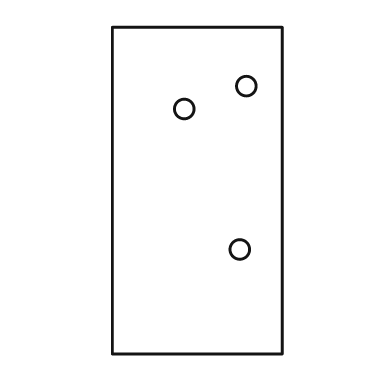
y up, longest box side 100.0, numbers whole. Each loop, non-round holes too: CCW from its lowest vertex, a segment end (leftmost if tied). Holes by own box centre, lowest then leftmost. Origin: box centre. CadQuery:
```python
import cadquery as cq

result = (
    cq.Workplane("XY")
    .moveTo(-26.0, -50.0)
    .lineTo(26.0, -50.0)
    .lineTo(26.0, 50.0)
    .lineTo(-26.0, 50.0)
    .close()
    .moveTo(13.0, -18.0)
    .circle(3.0)
    .moveTo(-4.0, 25.0)
    .circle(3.0)
    .moveTo(15.0, 32.0)
    .circle(3.0)
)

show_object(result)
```